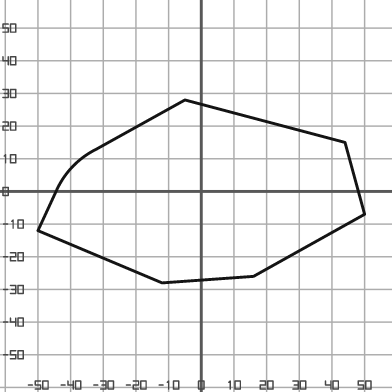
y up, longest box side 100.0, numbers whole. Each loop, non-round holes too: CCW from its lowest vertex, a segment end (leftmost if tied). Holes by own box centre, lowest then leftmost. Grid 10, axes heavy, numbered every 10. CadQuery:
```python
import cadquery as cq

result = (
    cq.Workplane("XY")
    .moveTo(-12.0, -28.0)
    .lineTo(16.0, -26.0)
    .lineTo(50.0, -7.0)
    .lineTo(44.0, 15.0)
    .lineTo(-5.0, 28.0)
    .lineTo(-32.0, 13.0)
    .threePointArc((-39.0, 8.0), (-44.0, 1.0))
    .lineTo(-50.0, -12.0)
    .close()
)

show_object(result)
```